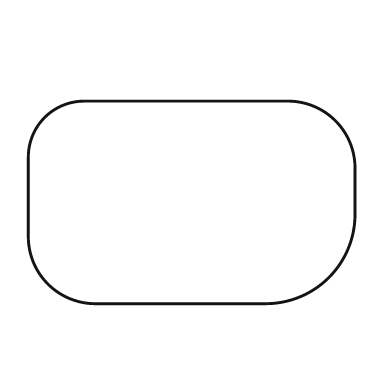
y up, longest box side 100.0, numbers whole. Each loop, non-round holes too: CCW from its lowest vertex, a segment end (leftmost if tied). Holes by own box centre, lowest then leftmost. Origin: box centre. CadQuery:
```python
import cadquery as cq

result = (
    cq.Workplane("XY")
    .moveTo(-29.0, -31.0)
    .lineTo(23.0, -31.0)
    .threePointArc((42.0, -23.0), (50.0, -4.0))
    .lineTo(50.0, 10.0)
    .threePointArc((44.0, 25.0), (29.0, 31.0))
    .lineTo(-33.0, 31.0)
    .threePointArc((-45.0, 26.0), (-50.0, 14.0))
    .lineTo(-50.0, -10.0)
    .threePointArc((-44.0, -25.0), (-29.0, -31.0))
    .close()
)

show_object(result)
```